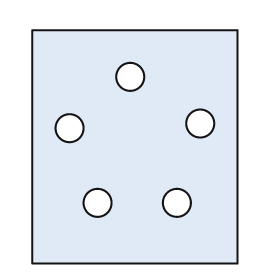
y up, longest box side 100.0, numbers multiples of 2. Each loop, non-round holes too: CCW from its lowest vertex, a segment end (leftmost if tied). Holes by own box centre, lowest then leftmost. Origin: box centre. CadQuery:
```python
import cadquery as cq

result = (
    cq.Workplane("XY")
    .moveTo(-44.0, -50.0)
    .lineTo(44.0, -50.0)
    .lineTo(44.0, 50.0)
    .lineTo(-44.0, 50.0)
    .close()
    .moveTo(-16.0, -24.0)
    .circle(6.0)
    .moveTo(18.0, -24.0)
    .circle(6.0)
    .moveTo(-28.0, 8.0)
    .circle(6.0)
    .moveTo(28.0, 10.0)
    .circle(6.0)
    .moveTo(-2.0, 30.0)
    .circle(6.0)
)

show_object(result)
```